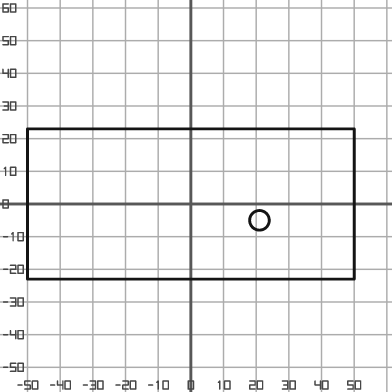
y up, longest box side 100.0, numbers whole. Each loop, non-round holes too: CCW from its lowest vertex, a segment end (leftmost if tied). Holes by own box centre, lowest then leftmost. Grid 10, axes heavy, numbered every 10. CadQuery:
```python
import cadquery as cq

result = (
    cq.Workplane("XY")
    .moveTo(-50.0, -23.0)
    .lineTo(50.0, -23.0)
    .lineTo(50.0, 23.0)
    .lineTo(-50.0, 23.0)
    .close()
    .moveTo(21.0, -5.0)
    .circle(3.0)
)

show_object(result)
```